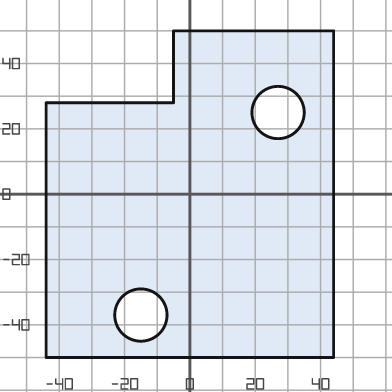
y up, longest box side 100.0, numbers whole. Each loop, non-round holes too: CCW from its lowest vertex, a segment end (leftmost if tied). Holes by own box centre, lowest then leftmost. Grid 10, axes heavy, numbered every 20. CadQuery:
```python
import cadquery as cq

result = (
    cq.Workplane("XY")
    .moveTo(-44.0, -50.0)
    .lineTo(44.0, -50.0)
    .lineTo(44.0, 50.0)
    .lineTo(-5.0, 50.0)
    .lineTo(-5.0, 28.0)
    .lineTo(-44.0, 28.0)
    .close()
    .moveTo(-15.0, -37.0)
    .circle(8.0)
    .moveTo(27.0, 25.0)
    .circle(8.0)
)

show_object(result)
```